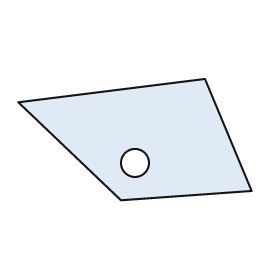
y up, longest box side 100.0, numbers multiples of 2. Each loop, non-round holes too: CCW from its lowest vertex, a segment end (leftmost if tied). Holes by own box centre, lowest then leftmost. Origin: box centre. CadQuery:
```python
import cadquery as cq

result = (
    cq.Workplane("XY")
    .moveTo(-6.0, -26.0)
    .lineTo(50.0, -22.0)
    .lineTo(30.0, 26.0)
    .lineTo(-50.0, 16.0)
    .close()
    .moveTo(0.0, -10.0)
    .circle(6.0)
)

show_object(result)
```